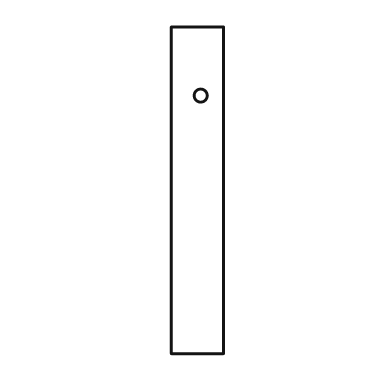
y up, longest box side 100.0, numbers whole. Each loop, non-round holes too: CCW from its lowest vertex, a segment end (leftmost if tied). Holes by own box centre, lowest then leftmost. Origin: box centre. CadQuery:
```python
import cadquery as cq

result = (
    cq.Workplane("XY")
    .moveTo(-8.0, -50.0)
    .lineTo(8.0, -50.0)
    .lineTo(8.0, 50.0)
    .lineTo(-8.0, 50.0)
    .close()
    .moveTo(1.0, 29.0)
    .circle(2.0)
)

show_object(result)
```